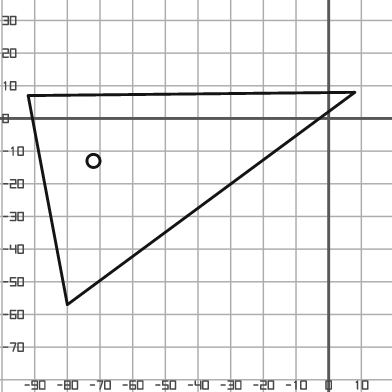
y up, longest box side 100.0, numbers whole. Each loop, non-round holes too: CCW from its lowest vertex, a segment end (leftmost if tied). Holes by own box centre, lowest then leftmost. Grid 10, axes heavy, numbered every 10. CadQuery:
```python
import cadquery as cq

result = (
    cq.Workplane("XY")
    .moveTo(-80.0, -57.0)
    .lineTo(8.0, 8.0)
    .lineTo(-92.0, 7.0)
    .close()
    .moveTo(-72.0, -13.0)
    .circle(2.0)
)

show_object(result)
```